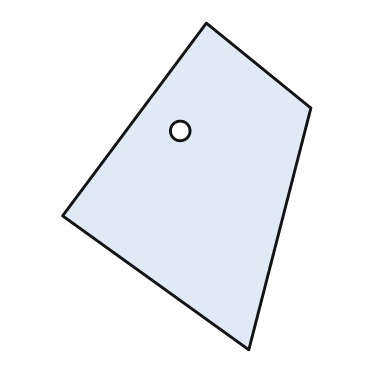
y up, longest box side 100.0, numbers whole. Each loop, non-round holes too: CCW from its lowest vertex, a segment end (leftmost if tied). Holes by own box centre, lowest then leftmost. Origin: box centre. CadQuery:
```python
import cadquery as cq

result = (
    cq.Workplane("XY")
    .moveTo(19.0, -50.0)
    .lineTo(38.0, 24.0)
    .lineTo(6.0, 50.0)
    .lineTo(-38.0, -9.0)
    .close()
    .moveTo(-2.0, 17.0)
    .circle(3.0)
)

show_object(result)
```